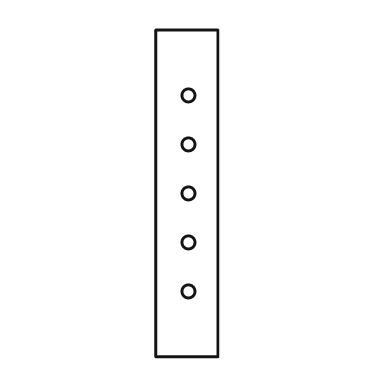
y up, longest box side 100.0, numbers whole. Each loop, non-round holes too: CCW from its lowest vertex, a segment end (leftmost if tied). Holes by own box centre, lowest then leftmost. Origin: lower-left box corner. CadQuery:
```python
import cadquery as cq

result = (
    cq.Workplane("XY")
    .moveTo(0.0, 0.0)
    .lineTo(19.0, 0.0)
    .lineTo(19.0, 100.0)
    .lineTo(0.0, 100.0)
    .close()
    .moveTo(10.0, 20.0)
    .circle(2.0)
    .moveTo(10.0, 35.0)
    .circle(2.0)
    .moveTo(10.0, 50.0)
    .circle(2.0)
    .moveTo(10.0, 65.0)
    .circle(2.0)
    .moveTo(10.0, 80.0)
    .circle(2.0)
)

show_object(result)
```